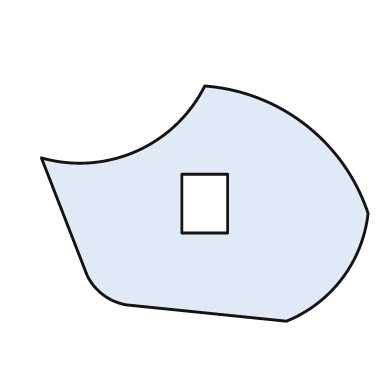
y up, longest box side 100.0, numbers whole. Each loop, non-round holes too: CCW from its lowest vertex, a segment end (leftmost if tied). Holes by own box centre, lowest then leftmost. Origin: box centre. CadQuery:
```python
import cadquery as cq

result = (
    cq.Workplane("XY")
    .moveTo(25.0, -36.0)
    .threePointArc((42.0, -23.0), (50.0, -3.0))
    .threePointArc((31.0, 24.0), (0.0, 36.0))
    .threePointArc((-21.0, 16.0), (-50.0, 14.0))
    .lineTo(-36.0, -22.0)
    .threePointArc((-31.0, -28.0), (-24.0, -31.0))
    .close()
    .moveTo(-7.0, -9.0)
    .lineTo(7.0, -9.0)
    .lineTo(7.0, 9.0)
    .lineTo(-7.0, 9.0)
    .close()
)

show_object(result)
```